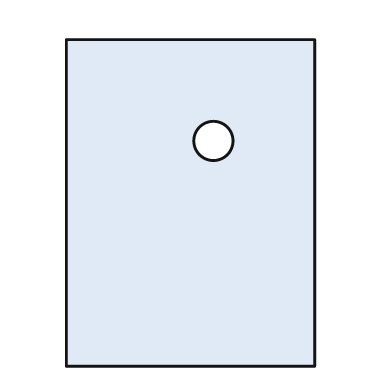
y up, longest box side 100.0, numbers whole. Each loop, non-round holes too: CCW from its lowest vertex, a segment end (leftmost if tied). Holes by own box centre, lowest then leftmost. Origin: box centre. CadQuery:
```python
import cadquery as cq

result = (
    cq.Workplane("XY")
    .moveTo(-38.0, -50.0)
    .lineTo(38.0, -50.0)
    .lineTo(38.0, 50.0)
    .lineTo(-38.0, 50.0)
    .close()
    .moveTo(7.0, 19.0)
    .circle(6.0)
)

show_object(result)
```